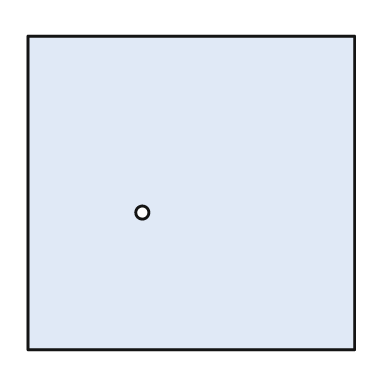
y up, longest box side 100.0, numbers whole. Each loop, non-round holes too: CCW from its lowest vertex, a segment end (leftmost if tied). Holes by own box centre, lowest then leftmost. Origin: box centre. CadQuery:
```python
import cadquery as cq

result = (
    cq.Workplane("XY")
    .moveTo(-50.0, -48.0)
    .lineTo(50.0, -48.0)
    .lineTo(50.0, 48.0)
    .lineTo(-50.0, 48.0)
    .close()
    .moveTo(-15.0, -6.0)
    .circle(2.0)
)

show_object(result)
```